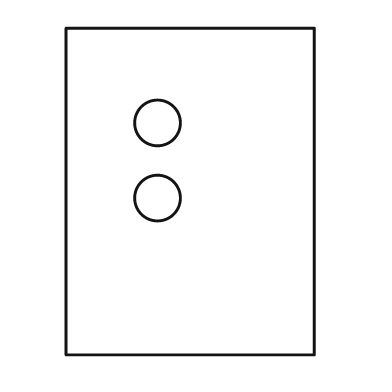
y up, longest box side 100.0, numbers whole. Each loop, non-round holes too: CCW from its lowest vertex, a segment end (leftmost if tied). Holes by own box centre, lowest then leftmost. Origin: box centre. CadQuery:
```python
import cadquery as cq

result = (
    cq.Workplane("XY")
    .moveTo(-38.0, -50.0)
    .lineTo(38.0, -50.0)
    .lineTo(38.0, 50.0)
    .lineTo(-38.0, 50.0)
    .close()
    .moveTo(-10.0, -2.0)
    .circle(7.0)
    .moveTo(-10.0, 21.0)
    .circle(7.0)
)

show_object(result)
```